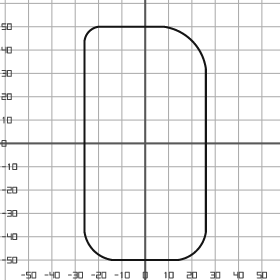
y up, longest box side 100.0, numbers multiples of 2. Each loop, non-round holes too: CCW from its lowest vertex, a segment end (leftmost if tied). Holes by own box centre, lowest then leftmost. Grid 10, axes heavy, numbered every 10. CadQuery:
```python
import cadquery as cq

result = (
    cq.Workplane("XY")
    .moveTo(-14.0, -50.0)
    .lineTo(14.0, -50.0)
    .threePointArc((22.0, -46.0), (26.0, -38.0))
    .lineTo(26.0, 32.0)
    .threePointArc((20.0, 44.0), (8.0, 50.0))
    .lineTo(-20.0, 50.0)
    .threePointArc((-24.0, 48.0), (-26.0, 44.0))
    .lineTo(-26.0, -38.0)
    .threePointArc((-22.0, -46.0), (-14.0, -50.0))
    .close()
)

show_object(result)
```